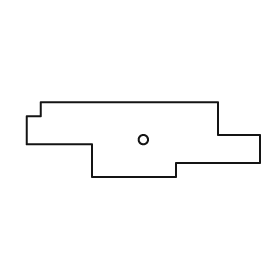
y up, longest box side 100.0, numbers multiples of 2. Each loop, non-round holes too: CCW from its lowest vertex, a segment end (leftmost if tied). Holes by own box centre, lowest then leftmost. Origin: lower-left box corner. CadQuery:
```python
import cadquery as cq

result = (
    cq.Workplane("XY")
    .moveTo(28.0, 0.0)
    .lineTo(64.0, 0.0)
    .lineTo(64.0, 6.0)
    .lineTo(100.0, 6.0)
    .lineTo(100.0, 18.0)
    .lineTo(82.0, 18.0)
    .lineTo(82.0, 32.0)
    .lineTo(6.0, 32.0)
    .lineTo(6.0, 26.0)
    .lineTo(0.0, 26.0)
    .lineTo(0.0, 14.0)
    .lineTo(28.0, 14.0)
    .close()
    .moveTo(50.0, 16.0)
    .circle(2.0)
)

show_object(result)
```